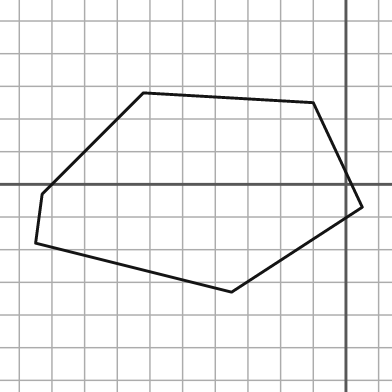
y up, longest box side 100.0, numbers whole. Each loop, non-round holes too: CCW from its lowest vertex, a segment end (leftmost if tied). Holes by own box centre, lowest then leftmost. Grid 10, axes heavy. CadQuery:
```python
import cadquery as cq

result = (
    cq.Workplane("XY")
    .moveTo(-35.0, -33.0)
    .lineTo(5.0, -7.0)
    .lineTo(-10.0, 25.0)
    .lineTo(-62.0, 28.0)
    .lineTo(-93.0, -3.0)
    .lineTo(-95.0, -18.0)
    .close()
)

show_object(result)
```